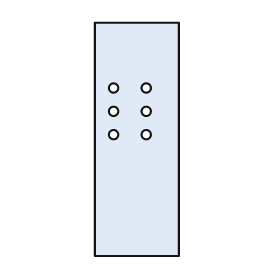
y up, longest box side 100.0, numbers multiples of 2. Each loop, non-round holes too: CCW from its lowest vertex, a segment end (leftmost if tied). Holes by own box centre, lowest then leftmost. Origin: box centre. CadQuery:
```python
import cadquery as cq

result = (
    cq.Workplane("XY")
    .moveTo(-18.0, -50.0)
    .lineTo(18.0, -50.0)
    .lineTo(18.0, 50.0)
    .lineTo(-18.0, 50.0)
    .close()
    .moveTo(-10.0, 2.0)
    .circle(2.0)
    .moveTo(4.0, 2.0)
    .circle(2.0)
    .moveTo(-10.0, 12.0)
    .circle(2.0)
    .moveTo(4.0, 12.0)
    .circle(2.0)
    .moveTo(-10.0, 22.0)
    .circle(2.0)
    .moveTo(4.0, 22.0)
    .circle(2.0)
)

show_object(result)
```